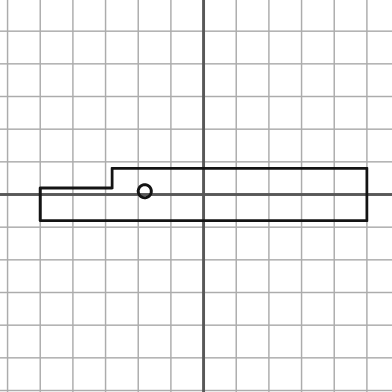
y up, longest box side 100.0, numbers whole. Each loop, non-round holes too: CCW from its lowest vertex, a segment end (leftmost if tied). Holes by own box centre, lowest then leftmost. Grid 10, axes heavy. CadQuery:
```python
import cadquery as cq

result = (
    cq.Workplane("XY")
    .moveTo(-50.0, -8.0)
    .lineTo(50.0, -8.0)
    .lineTo(50.0, 8.0)
    .lineTo(-28.0, 8.0)
    .lineTo(-28.0, 2.0)
    .lineTo(-50.0, 2.0)
    .close()
    .moveTo(-18.0, 1.0)
    .circle(2.0)
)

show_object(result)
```